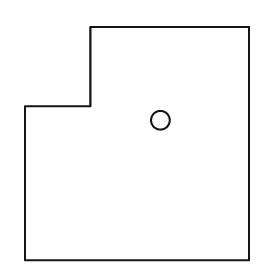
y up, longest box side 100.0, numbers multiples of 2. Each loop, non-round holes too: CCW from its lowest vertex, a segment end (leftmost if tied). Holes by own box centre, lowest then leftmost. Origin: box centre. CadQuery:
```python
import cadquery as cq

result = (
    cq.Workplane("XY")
    .moveTo(-48.0, -50.0)
    .lineTo(48.0, -50.0)
    .lineTo(48.0, 50.0)
    .lineTo(-20.0, 50.0)
    .lineTo(-20.0, 16.0)
    .lineTo(-48.0, 16.0)
    .close()
    .moveTo(10.0, 10.0)
    .circle(4.0)
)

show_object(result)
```